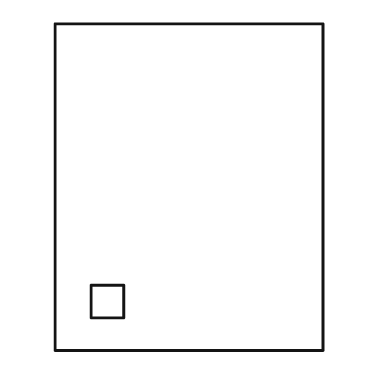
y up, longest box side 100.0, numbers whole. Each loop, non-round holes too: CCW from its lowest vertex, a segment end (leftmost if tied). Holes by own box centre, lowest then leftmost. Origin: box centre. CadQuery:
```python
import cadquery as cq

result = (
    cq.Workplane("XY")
    .moveTo(-41.0, -50.0)
    .lineTo(41.0, -50.0)
    .lineTo(41.0, 50.0)
    .lineTo(-41.0, 50.0)
    .close()
    .moveTo(-30.0, -40.0)
    .lineTo(-20.0, -40.0)
    .lineTo(-20.0, -30.0)
    .lineTo(-30.0, -30.0)
    .close()
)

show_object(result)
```